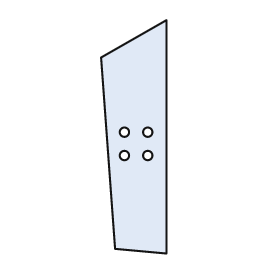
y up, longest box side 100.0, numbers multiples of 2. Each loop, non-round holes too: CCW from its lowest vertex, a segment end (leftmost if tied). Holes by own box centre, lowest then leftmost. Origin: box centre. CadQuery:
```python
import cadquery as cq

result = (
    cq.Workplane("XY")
    .moveTo(14.0, -50.0)
    .lineTo(14.0, 50.0)
    .lineTo(-14.0, 34.0)
    .lineTo(-8.0, -48.0)
    .close()
    .moveTo(-4.0, -8.0)
    .circle(2.0)
    .moveTo(6.0, -8.0)
    .circle(2.0)
    .moveTo(-4.0, 2.0)
    .circle(2.0)
    .moveTo(6.0, 2.0)
    .circle(2.0)
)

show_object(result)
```